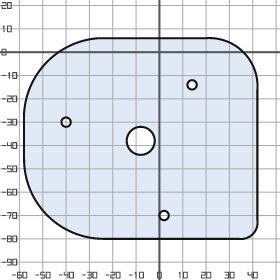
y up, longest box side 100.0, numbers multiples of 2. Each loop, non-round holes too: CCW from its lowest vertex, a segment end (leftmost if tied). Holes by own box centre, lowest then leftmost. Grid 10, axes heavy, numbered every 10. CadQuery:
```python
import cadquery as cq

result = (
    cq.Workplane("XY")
    .moveTo(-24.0, -80.0)
    .lineTo(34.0, -80.0)
    .threePointArc((40.0, -78.0), (42.0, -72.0))
    .lineTo(42.0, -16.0)
    .threePointArc((36.0, 0.0), (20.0, 6.0))
    .lineTo(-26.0, 6.0)
    .threePointArc((-48.0, -4.0), (-58.0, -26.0))
    .lineTo(-58.0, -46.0)
    .threePointArc((-48.0, -70.0), (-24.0, -80.0))
    .close()
    .moveTo(2.0, -70.0)
    .circle(2.0)
    .moveTo(-8.0, -38.0)
    .circle(6.0)
    .moveTo(-40.0, -30.0)
    .circle(2.0)
    .moveTo(14.0, -14.0)
    .circle(2.0)
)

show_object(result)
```